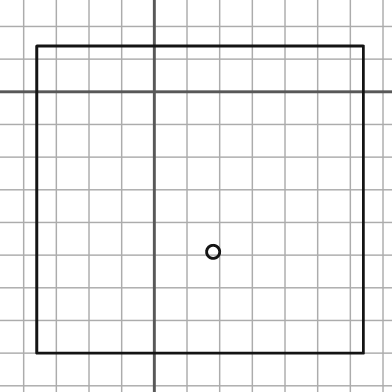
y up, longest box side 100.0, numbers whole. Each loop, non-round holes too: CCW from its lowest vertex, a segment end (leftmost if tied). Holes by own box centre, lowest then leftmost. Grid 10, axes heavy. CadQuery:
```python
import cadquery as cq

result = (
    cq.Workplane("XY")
    .moveTo(-36.0, -80.0)
    .lineTo(64.0, -80.0)
    .lineTo(64.0, 14.0)
    .lineTo(-36.0, 14.0)
    .close()
    .moveTo(18.0, -49.0)
    .circle(2.0)
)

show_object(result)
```